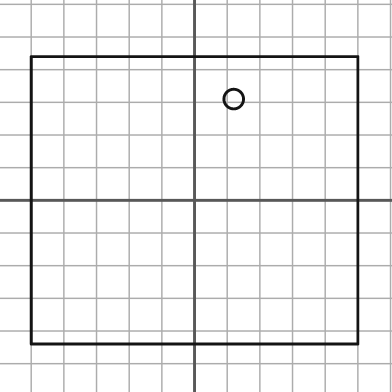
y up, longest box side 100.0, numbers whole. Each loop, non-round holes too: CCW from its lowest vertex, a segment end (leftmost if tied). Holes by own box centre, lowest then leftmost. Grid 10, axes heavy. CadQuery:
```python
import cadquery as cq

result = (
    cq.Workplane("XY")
    .moveTo(-50.0, -44.0)
    .lineTo(50.0, -44.0)
    .lineTo(50.0, 44.0)
    .lineTo(-50.0, 44.0)
    .close()
    .moveTo(12.0, 31.0)
    .circle(3.0)
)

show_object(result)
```